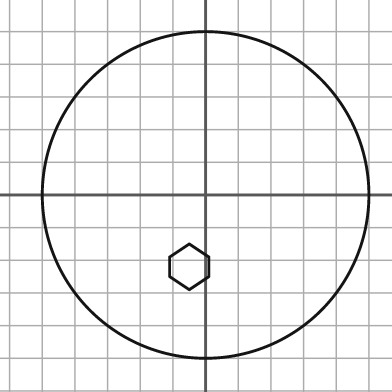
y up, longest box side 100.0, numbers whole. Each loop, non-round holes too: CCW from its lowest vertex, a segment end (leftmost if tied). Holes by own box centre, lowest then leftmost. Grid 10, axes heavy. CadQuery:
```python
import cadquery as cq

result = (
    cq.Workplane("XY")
    .moveTo(0.0, 0.0)
    .circle(50.0)
    .moveTo(-5.0, -29.0)
    .lineTo(1.0, -25.0)
    .lineTo(1.0, -19.0)
    .lineTo(-5.0, -15.0)
    .lineTo(-11.0, -19.0)
    .lineTo(-11.0, -25.0)
    .close()
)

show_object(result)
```